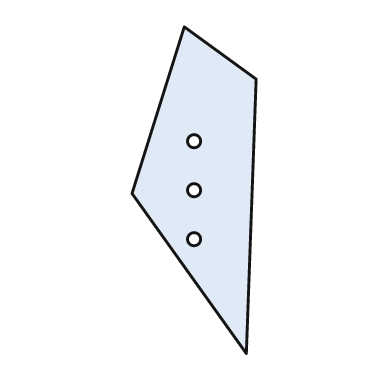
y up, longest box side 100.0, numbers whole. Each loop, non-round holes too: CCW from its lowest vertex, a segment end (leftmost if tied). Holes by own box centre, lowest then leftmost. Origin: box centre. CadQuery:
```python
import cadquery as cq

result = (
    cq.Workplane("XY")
    .moveTo(16.0, -50.0)
    .lineTo(19.0, 34.0)
    .lineTo(-3.0, 50.0)
    .lineTo(-19.0, -1.0)
    .close()
    .moveTo(0.0, -15.0)
    .circle(2.0)
    .moveTo(0.0, 0.0)
    .circle(2.0)
    .moveTo(0.0, 15.0)
    .circle(2.0)
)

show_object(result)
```